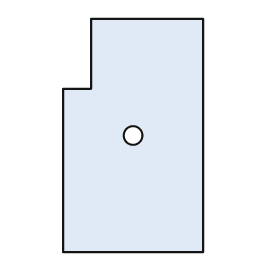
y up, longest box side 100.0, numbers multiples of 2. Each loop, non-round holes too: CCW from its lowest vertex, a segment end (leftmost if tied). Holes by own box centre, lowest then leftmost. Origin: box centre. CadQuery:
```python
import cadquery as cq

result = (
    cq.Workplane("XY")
    .moveTo(-30.0, -50.0)
    .lineTo(30.0, -50.0)
    .lineTo(30.0, 50.0)
    .lineTo(-18.0, 50.0)
    .lineTo(-18.0, 20.0)
    .lineTo(-30.0, 20.0)
    .close()
    .moveTo(0.0, 0.0)
    .circle(4.0)
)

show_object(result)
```